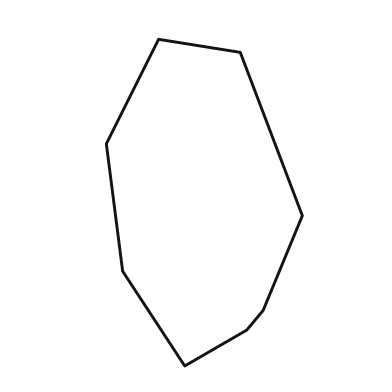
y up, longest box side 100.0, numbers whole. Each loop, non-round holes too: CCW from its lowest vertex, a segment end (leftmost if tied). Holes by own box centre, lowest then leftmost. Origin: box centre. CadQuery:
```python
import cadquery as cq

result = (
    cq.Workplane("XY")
    .moveTo(-6.0, -50.0)
    .lineTo(13.0, -39.0)
    .lineTo(18.0, -33.0)
    .lineTo(30.0, -4.0)
    .lineTo(11.0, 46.0)
    .lineTo(-14.0, 50.0)
    .lineTo(-30.0, 18.0)
    .lineTo(-25.0, -21.0)
    .close()
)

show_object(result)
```